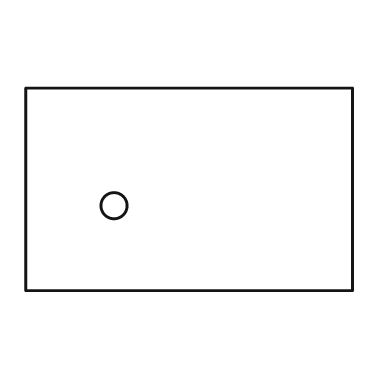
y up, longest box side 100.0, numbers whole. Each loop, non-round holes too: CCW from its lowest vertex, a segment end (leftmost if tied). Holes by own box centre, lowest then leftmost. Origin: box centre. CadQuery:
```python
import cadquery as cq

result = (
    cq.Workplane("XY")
    .moveTo(-50.0, -31.0)
    .lineTo(50.0, -31.0)
    .lineTo(50.0, 31.0)
    .lineTo(-50.0, 31.0)
    .close()
    .moveTo(-23.0, -5.0)
    .circle(4.0)
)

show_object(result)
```